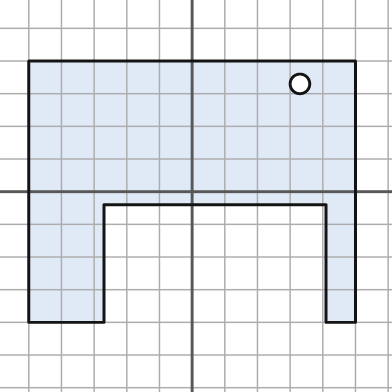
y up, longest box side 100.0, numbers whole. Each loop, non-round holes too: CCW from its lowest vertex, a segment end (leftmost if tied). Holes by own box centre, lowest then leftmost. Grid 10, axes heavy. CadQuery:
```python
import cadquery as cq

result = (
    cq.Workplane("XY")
    .moveTo(-50.0, -40.0)
    .lineTo(-27.0, -40.0)
    .lineTo(-27.0, -4.0)
    .lineTo(41.0, -4.0)
    .lineTo(41.0, -40.0)
    .lineTo(50.0, -40.0)
    .lineTo(50.0, 40.0)
    .lineTo(-50.0, 40.0)
    .close()
    .moveTo(33.0, 33.0)
    .circle(3.0)
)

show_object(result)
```